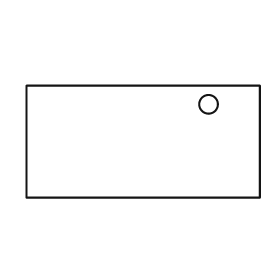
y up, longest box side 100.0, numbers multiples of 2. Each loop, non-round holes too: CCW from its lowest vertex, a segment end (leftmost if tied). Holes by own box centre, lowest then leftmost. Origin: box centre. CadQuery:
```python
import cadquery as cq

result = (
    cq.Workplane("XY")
    .moveTo(-50.0, -24.0)
    .lineTo(50.0, -24.0)
    .lineTo(50.0, 24.0)
    .lineTo(-50.0, 24.0)
    .close()
    .moveTo(28.0, 16.0)
    .circle(4.0)
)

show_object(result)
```